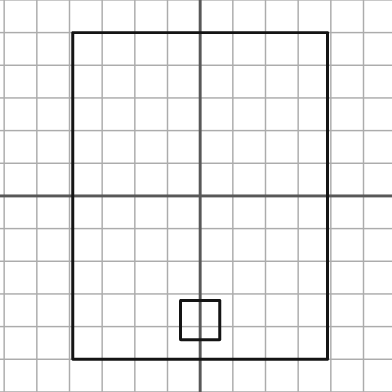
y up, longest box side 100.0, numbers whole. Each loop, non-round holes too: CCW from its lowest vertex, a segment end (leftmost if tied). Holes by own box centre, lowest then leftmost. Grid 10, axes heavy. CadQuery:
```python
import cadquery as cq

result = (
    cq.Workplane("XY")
    .moveTo(-39.0, -50.0)
    .lineTo(39.0, -50.0)
    .lineTo(39.0, 50.0)
    .lineTo(-39.0, 50.0)
    .close()
    .moveTo(-6.0, -44.0)
    .lineTo(6.0, -44.0)
    .lineTo(6.0, -32.0)
    .lineTo(-6.0, -32.0)
    .close()
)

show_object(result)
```